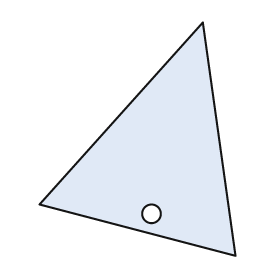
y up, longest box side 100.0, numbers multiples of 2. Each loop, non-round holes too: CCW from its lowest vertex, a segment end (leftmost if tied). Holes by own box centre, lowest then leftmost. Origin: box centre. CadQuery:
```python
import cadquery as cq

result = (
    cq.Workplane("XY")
    .moveTo(42.0, -50.0)
    .lineTo(28.0, 50.0)
    .lineTo(-42.0, -28.0)
    .close()
    .moveTo(6.0, -32.0)
    .circle(4.0)
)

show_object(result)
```